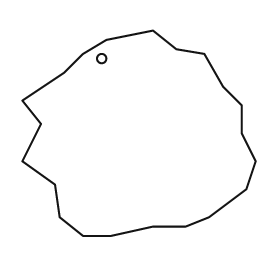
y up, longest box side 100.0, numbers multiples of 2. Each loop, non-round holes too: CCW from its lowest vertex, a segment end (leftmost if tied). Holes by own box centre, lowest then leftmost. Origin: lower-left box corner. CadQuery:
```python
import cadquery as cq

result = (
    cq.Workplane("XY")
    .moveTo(26.0, 0.0)
    .lineTo(38.0, 0.0)
    .lineTo(56.0, 4.0)
    .lineTo(70.0, 4.0)
    .lineTo(80.0, 8.0)
    .lineTo(96.0, 20.0)
    .lineTo(100.0, 32.0)
    .lineTo(94.0, 44.0)
    .lineTo(94.0, 56.0)
    .lineTo(86.0, 64.0)
    .lineTo(78.0, 78.0)
    .lineTo(66.0, 80.0)
    .lineTo(56.0, 88.0)
    .lineTo(36.0, 84.0)
    .lineTo(26.0, 78.0)
    .lineTo(18.0, 70.0)
    .lineTo(0.0, 58.0)
    .lineTo(8.0, 48.0)
    .lineTo(0.0, 32.0)
    .lineTo(14.0, 22.0)
    .lineTo(16.0, 8.0)
    .close()
    .moveTo(34.0, 76.0)
    .circle(2.0)
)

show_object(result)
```